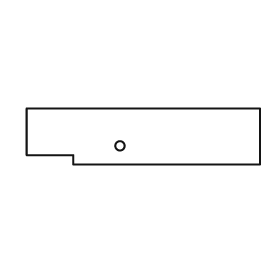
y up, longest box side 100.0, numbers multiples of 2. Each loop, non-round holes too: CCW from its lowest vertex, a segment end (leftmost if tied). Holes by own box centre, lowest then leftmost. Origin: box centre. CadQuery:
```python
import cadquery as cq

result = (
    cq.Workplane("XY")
    .moveTo(-30.0, -12.0)
    .lineTo(50.0, -12.0)
    .lineTo(50.0, 12.0)
    .lineTo(-50.0, 12.0)
    .lineTo(-50.0, -8.0)
    .lineTo(-30.0, -8.0)
    .close()
    .moveTo(-10.0, -4.0)
    .circle(2.0)
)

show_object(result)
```